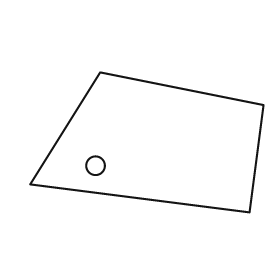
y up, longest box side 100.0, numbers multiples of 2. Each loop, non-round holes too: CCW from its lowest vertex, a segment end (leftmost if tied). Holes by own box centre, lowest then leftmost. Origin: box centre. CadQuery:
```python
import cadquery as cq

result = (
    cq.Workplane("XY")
    .moveTo(44.0, -30.0)
    .lineTo(50.0, 16.0)
    .lineTo(-20.0, 30.0)
    .lineTo(-50.0, -18.0)
    .close()
    .moveTo(-22.0, -10.0)
    .circle(4.0)
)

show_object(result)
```